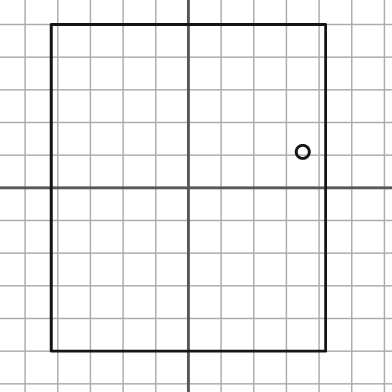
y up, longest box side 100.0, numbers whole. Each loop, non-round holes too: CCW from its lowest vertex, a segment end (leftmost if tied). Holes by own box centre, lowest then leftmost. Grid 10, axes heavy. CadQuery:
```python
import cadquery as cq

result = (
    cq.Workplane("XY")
    .moveTo(-42.0, -50.0)
    .lineTo(42.0, -50.0)
    .lineTo(42.0, 50.0)
    .lineTo(-42.0, 50.0)
    .close()
    .moveTo(35.0, 11.0)
    .circle(2.0)
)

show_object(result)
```